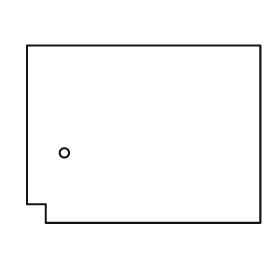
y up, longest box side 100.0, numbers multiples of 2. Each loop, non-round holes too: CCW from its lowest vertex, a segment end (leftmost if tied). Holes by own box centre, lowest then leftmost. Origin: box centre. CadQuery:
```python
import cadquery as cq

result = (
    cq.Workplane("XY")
    .moveTo(-42.0, -38.0)
    .lineTo(50.0, -38.0)
    .lineTo(50.0, 38.0)
    .lineTo(-50.0, 38.0)
    .lineTo(-50.0, -30.0)
    .lineTo(-42.0, -30.0)
    .close()
    .moveTo(-34.0, -8.0)
    .circle(2.0)
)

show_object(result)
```